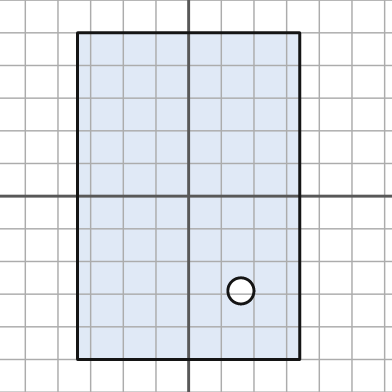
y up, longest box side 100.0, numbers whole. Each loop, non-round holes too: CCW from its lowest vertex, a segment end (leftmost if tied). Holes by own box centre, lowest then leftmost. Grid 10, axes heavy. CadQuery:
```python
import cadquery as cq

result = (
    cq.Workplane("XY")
    .moveTo(-34.0, -50.0)
    .lineTo(34.0, -50.0)
    .lineTo(34.0, 50.0)
    .lineTo(-34.0, 50.0)
    .close()
    .moveTo(16.0, -29.0)
    .circle(4.0)
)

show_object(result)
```